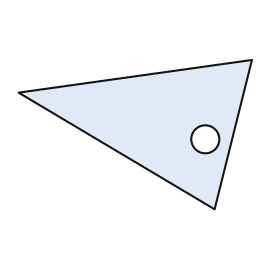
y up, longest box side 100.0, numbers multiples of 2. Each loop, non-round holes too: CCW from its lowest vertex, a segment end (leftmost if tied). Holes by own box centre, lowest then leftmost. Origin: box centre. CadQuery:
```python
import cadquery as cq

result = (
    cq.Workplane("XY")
    .moveTo(34.0, -32.0)
    .lineTo(50.0, 32.0)
    .lineTo(-50.0, 18.0)
    .close()
    .moveTo(30.0, -2.0)
    .circle(6.0)
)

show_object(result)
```